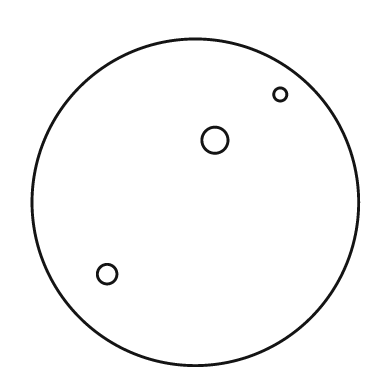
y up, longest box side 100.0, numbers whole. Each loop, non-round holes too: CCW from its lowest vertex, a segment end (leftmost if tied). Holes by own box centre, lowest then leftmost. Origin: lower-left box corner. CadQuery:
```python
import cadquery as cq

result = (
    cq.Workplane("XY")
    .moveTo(50.0, 50.0)
    .circle(50.0)
    .moveTo(23.0, 28.0)
    .circle(3.0)
    .moveTo(56.0, 69.0)
    .circle(4.0)
    .moveTo(76.0, 83.0)
    .circle(2.0)
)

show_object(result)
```